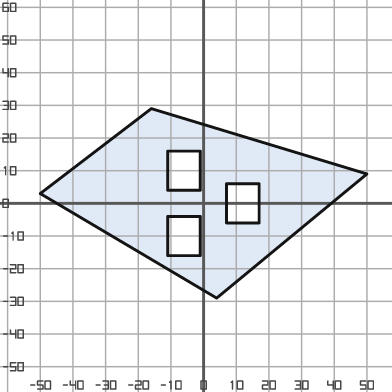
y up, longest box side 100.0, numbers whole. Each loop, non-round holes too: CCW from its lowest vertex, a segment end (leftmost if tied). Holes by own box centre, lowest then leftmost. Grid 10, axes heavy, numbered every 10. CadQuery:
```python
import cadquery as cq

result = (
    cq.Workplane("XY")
    .moveTo(4.0, -29.0)
    .lineTo(50.0, 9.0)
    .lineTo(-16.0, 29.0)
    .lineTo(-50.0, 3.0)
    .close()
    .moveTo(-11.0, -16.0)
    .lineTo(-1.0, -16.0)
    .lineTo(-1.0, -4.0)
    .lineTo(-11.0, -4.0)
    .close()
    .moveTo(7.0, -6.0)
    .lineTo(17.0, -6.0)
    .lineTo(17.0, 6.0)
    .lineTo(7.0, 6.0)
    .close()
    .moveTo(-11.0, 4.0)
    .lineTo(-1.0, 4.0)
    .lineTo(-1.0, 16.0)
    .lineTo(-11.0, 16.0)
    .close()
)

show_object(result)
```